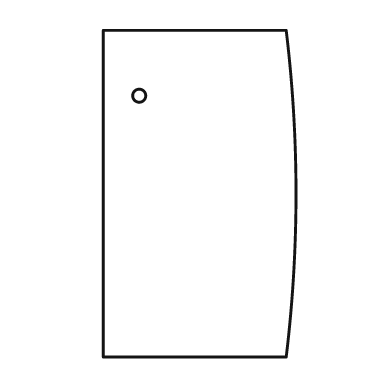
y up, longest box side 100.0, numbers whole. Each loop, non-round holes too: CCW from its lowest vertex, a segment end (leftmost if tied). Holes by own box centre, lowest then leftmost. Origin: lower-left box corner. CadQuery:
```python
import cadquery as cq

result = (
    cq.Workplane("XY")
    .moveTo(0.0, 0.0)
    .lineTo(56.0, 0.0)
    .threePointArc((59.0, 50.0), (56.0, 100.0))
    .lineTo(0.0, 100.0)
    .close()
    .moveTo(11.0, 80.0)
    .circle(2.0)
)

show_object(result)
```